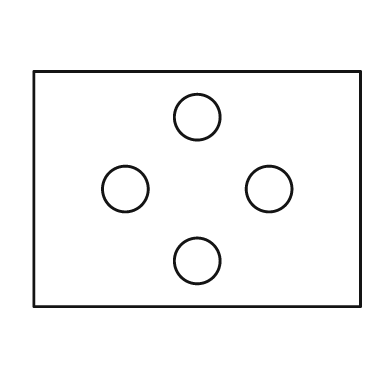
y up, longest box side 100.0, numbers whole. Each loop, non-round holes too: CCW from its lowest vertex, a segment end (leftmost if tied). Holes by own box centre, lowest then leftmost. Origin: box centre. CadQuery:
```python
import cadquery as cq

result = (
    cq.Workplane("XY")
    .moveTo(-50.0, -36.0)
    .lineTo(50.0, -36.0)
    .lineTo(50.0, 36.0)
    .lineTo(-50.0, 36.0)
    .close()
    .moveTo(0.0, -22.0)
    .circle(7.0)
    .moveTo(-22.0, 0.0)
    .circle(7.0)
    .moveTo(22.0, 0.0)
    .circle(7.0)
    .moveTo(0.0, 22.0)
    .circle(7.0)
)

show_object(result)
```